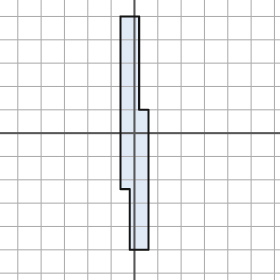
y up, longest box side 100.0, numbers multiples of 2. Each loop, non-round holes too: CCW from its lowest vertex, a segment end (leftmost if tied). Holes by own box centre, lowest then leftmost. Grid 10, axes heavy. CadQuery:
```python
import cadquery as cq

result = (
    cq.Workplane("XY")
    .moveTo(-2.0, -50.0)
    .lineTo(6.0, -50.0)
    .lineTo(6.0, 10.0)
    .lineTo(2.0, 10.0)
    .lineTo(2.0, 50.0)
    .lineTo(-6.0, 50.0)
    .lineTo(-6.0, -24.0)
    .lineTo(-2.0, -24.0)
    .close()
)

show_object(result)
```